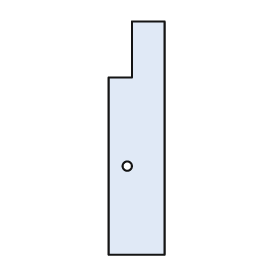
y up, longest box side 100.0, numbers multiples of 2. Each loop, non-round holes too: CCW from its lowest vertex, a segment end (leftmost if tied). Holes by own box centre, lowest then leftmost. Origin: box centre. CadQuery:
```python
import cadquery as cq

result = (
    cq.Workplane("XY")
    .moveTo(-12.0, -50.0)
    .lineTo(12.0, -50.0)
    .lineTo(12.0, 50.0)
    .lineTo(-2.0, 50.0)
    .lineTo(-2.0, 26.0)
    .lineTo(-12.0, 26.0)
    .close()
    .moveTo(-4.0, -12.0)
    .circle(2.0)
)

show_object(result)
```